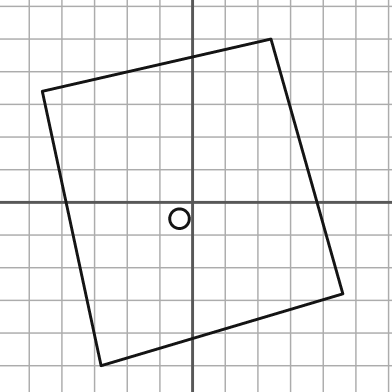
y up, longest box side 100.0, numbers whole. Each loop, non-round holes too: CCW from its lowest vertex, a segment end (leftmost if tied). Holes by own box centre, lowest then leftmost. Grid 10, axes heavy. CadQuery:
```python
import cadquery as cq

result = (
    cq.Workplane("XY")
    .moveTo(-28.0, -50.0)
    .lineTo(46.0, -28.0)
    .lineTo(24.0, 50.0)
    .lineTo(-46.0, 34.0)
    .close()
    .moveTo(-4.0, -5.0)
    .circle(3.0)
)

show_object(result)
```